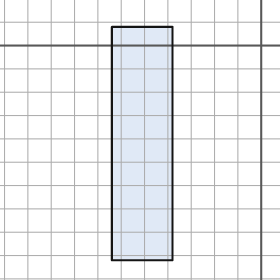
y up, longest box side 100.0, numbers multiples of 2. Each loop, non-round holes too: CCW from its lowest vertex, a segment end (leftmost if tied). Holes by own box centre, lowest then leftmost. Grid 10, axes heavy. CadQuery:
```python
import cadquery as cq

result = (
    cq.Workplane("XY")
    .moveTo(-64.0, -92.0)
    .lineTo(-38.0, -92.0)
    .lineTo(-38.0, 8.0)
    .lineTo(-64.0, 8.0)
    .close()
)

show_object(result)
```